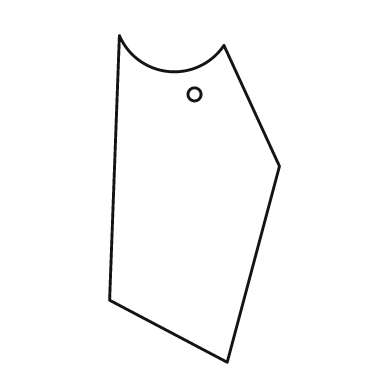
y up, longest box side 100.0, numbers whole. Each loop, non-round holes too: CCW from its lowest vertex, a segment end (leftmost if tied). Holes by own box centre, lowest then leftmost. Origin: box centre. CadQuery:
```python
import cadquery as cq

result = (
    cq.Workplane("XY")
    .moveTo(10.0, -50.0)
    .lineTo(26.0, 10.0)
    .lineTo(9.0, 47.0)
    .threePointArc((-8.0, 39.0), (-23.0, 50.0))
    .lineTo(-26.0, -31.0)
    .close()
    .moveTo(0.0, 32.0)
    .circle(2.0)
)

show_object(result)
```